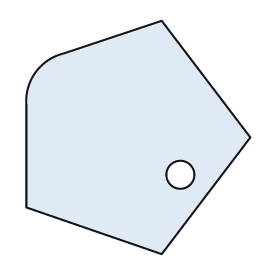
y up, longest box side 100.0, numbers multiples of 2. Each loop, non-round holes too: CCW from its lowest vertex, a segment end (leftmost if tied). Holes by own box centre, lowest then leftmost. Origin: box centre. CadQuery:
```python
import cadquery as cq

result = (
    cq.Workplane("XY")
    .moveTo(10.0, -50.0)
    .lineTo(48.0, 0.0)
    .lineTo(10.0, 50.0)
    .lineTo(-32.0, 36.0)
    .threePointArc((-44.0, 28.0), (-48.0, 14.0))
    .lineTo(-48.0, -30.0)
    .close()
    .moveTo(18.0, -16.0)
    .circle(6.0)
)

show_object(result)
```